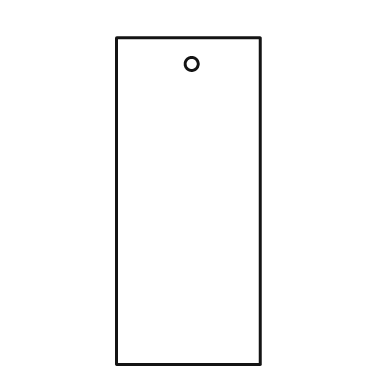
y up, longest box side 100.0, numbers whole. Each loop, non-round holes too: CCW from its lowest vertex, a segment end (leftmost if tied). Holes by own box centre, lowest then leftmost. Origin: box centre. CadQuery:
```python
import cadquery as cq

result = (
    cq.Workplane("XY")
    .moveTo(-22.0, -50.0)
    .lineTo(22.0, -50.0)
    .lineTo(22.0, 50.0)
    .lineTo(-22.0, 50.0)
    .close()
    .moveTo(1.0, 42.0)
    .circle(2.0)
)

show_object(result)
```